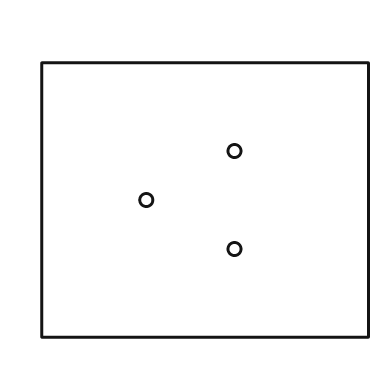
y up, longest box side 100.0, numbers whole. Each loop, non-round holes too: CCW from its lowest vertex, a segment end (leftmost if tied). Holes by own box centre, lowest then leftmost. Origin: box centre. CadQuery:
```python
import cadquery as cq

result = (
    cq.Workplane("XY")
    .moveTo(-50.0, -42.0)
    .lineTo(50.0, -42.0)
    .lineTo(50.0, 42.0)
    .lineTo(-50.0, 42.0)
    .close()
    .moveTo(9.0, -15.0)
    .circle(2.0)
    .moveTo(-18.0, 0.0)
    .circle(2.0)
    .moveTo(9.0, 15.0)
    .circle(2.0)
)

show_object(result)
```